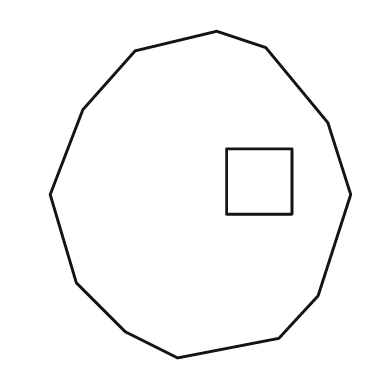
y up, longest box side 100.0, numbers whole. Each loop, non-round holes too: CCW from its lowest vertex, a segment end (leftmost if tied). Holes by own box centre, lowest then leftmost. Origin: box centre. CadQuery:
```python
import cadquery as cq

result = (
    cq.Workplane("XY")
    .moveTo(-7.0, -50.0)
    .lineTo(24.0, -44.0)
    .lineTo(36.0, -31.0)
    .lineTo(46.0, 0.0)
    .lineTo(39.0, 22.0)
    .lineTo(20.0, 45.0)
    .lineTo(5.0, 50.0)
    .lineTo(-20.0, 44.0)
    .lineTo(-36.0, 26.0)
    .lineTo(-46.0, 0.0)
    .lineTo(-38.0, -27.0)
    .lineTo(-23.0, -42.0)
    .close()
    .moveTo(8.0, -6.0)
    .lineTo(28.0, -6.0)
    .lineTo(28.0, 14.0)
    .lineTo(8.0, 14.0)
    .close()
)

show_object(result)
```